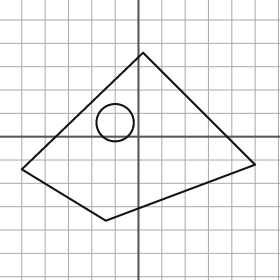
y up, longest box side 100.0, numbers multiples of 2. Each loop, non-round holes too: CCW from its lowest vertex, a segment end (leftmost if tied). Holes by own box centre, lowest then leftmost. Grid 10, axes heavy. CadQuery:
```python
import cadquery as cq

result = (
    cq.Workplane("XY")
    .moveTo(-14.0, -36.0)
    .lineTo(50.0, -12.0)
    .lineTo(2.0, 36.0)
    .lineTo(-50.0, -14.0)
    .close()
    .moveTo(-10.0, 6.0)
    .circle(8.0)
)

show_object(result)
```